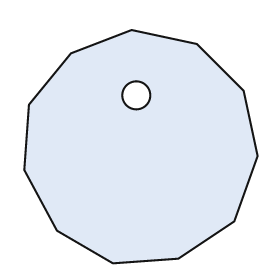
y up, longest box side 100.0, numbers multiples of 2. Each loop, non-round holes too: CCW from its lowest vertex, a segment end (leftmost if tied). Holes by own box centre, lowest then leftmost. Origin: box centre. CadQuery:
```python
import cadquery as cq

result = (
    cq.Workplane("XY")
    .moveTo(-12.0, -50.0)
    .lineTo(16.0, -48.0)
    .lineTo(40.0, -32.0)
    .lineTo(50.0, -4.0)
    .lineTo(44.0, 24.0)
    .lineTo(24.0, 44.0)
    .lineTo(-4.0, 50.0)
    .lineTo(-30.0, 40.0)
    .lineTo(-48.0, 18.0)
    .lineTo(-50.0, -10.0)
    .lineTo(-36.0, -36.0)
    .close()
    .moveTo(-2.0, 22.0)
    .circle(6.0)
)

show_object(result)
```